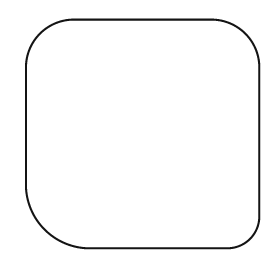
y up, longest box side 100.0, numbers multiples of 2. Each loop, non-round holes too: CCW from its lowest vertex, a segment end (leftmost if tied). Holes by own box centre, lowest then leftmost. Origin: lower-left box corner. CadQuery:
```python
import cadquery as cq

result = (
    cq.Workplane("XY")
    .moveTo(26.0, 0.0)
    .lineTo(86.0, 0.0)
    .threePointArc((96.0, 4.0), (100.0, 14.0))
    .lineTo(100.0, 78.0)
    .threePointArc((94.0, 92.0), (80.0, 98.0))
    .lineTo(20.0, 98.0)
    .threePointArc((6.0, 92.0), (0.0, 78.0))
    .lineTo(0.0, 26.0)
    .threePointArc((8.0, 8.0), (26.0, 0.0))
    .close()
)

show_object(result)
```